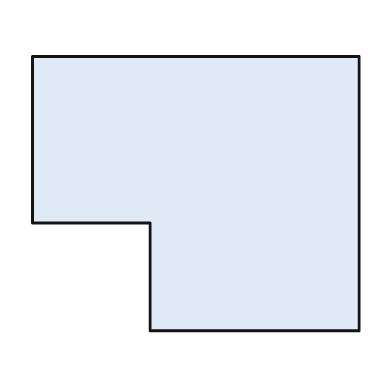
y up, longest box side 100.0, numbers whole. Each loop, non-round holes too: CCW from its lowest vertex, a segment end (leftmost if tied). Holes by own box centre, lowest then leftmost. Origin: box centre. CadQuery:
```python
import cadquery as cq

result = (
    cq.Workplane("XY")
    .moveTo(-14.0, -42.0)
    .lineTo(50.0, -42.0)
    .lineTo(50.0, 42.0)
    .lineTo(-50.0, 42.0)
    .lineTo(-50.0, -9.0)
    .lineTo(-14.0, -9.0)
    .close()
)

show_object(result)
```